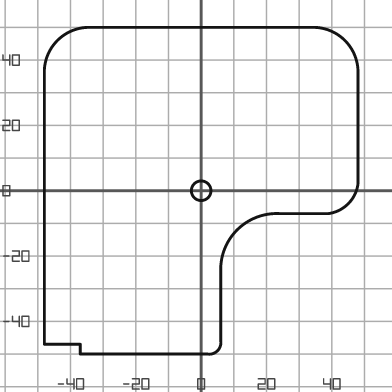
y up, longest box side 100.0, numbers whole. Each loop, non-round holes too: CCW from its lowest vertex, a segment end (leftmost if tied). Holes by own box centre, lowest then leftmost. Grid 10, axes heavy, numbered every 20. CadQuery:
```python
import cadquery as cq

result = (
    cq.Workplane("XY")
    .moveTo(-37.0, -50.0)
    .lineTo(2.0, -50.0)
    .threePointArc((5.0, -49.0), (6.0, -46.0))
    .lineTo(6.0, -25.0)
    .threePointArc((11.0, -12.0), (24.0, -7.0))
    .lineTo(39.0, -7.0)
    .threePointArc((45.0, -4.0), (48.0, 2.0))
    .lineTo(48.0, 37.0)
    .threePointArc((44.0, 46.0), (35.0, 50.0))
    .lineTo(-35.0, 50.0)
    .threePointArc((-44.0, 46.0), (-48.0, 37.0))
    .lineTo(-48.0, -47.0)
    .lineTo(-37.0, -47.0)
    .close()
    .moveTo(0.0, 0.0)
    .circle(3.0)
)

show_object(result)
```